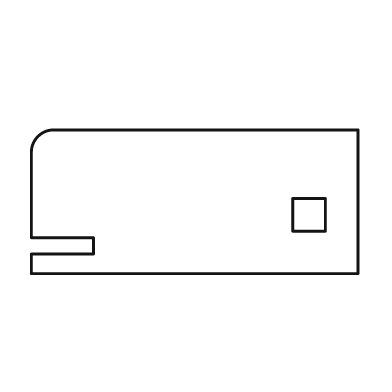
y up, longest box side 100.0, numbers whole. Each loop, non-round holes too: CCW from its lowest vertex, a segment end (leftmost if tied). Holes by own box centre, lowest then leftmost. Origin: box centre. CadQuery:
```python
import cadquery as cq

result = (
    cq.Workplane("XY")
    .moveTo(-50.0, -22.0)
    .lineTo(50.0, -22.0)
    .lineTo(50.0, 22.0)
    .lineTo(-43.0, 22.0)
    .threePointArc((-48.0, 20.0), (-50.0, 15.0))
    .lineTo(-50.0, -11.0)
    .lineTo(-31.0, -11.0)
    .lineTo(-31.0, -16.0)
    .lineTo(-50.0, -16.0)
    .close()
    .moveTo(30.0, -9.0)
    .lineTo(40.0, -9.0)
    .lineTo(40.0, 1.0)
    .lineTo(30.0, 1.0)
    .close()
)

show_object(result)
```